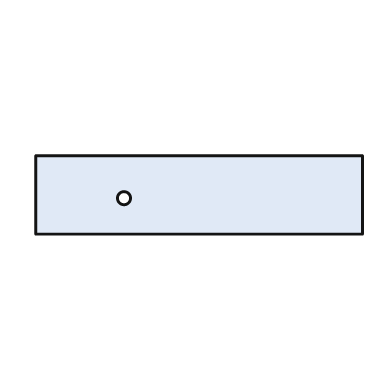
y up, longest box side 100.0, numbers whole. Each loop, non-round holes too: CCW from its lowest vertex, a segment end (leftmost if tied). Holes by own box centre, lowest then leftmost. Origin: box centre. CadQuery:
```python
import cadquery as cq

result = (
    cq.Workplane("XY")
    .moveTo(-50.0, -12.0)
    .lineTo(50.0, -12.0)
    .lineTo(50.0, 12.0)
    .lineTo(-50.0, 12.0)
    .close()
    .moveTo(-23.0, -1.0)
    .circle(2.0)
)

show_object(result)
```